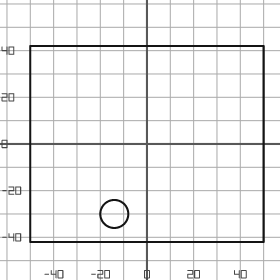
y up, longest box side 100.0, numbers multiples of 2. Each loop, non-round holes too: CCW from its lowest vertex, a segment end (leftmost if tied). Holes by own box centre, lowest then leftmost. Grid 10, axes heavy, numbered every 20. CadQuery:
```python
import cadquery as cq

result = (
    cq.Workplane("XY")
    .moveTo(-50.0, -42.0)
    .lineTo(50.0, -42.0)
    .lineTo(50.0, 42.0)
    .lineTo(-50.0, 42.0)
    .close()
    .moveTo(-14.0, -30.0)
    .circle(6.0)
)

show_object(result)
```